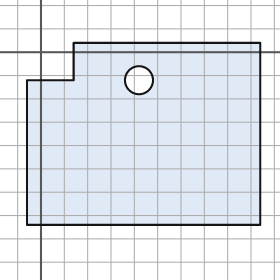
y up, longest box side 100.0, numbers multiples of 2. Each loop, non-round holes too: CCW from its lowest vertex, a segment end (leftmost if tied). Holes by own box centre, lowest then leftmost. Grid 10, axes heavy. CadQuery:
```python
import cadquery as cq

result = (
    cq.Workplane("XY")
    .moveTo(-6.0, -74.0)
    .lineTo(94.0, -74.0)
    .lineTo(94.0, 4.0)
    .lineTo(14.0, 4.0)
    .lineTo(14.0, -12.0)
    .lineTo(-6.0, -12.0)
    .close()
    .moveTo(42.0, -12.0)
    .circle(6.0)
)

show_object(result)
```